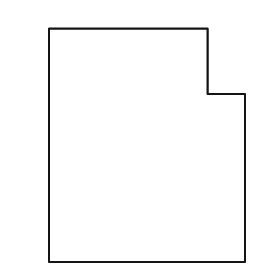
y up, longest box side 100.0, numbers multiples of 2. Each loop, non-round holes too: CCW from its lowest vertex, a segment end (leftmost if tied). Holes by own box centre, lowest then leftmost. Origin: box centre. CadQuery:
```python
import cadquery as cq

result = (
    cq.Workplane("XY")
    .moveTo(-42.0, -50.0)
    .lineTo(42.0, -50.0)
    .lineTo(42.0, 22.0)
    .lineTo(26.0, 22.0)
    .lineTo(26.0, 50.0)
    .lineTo(-42.0, 50.0)
    .close()
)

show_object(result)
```